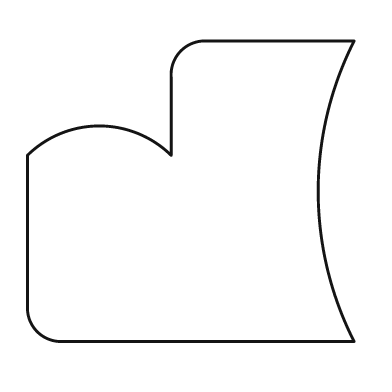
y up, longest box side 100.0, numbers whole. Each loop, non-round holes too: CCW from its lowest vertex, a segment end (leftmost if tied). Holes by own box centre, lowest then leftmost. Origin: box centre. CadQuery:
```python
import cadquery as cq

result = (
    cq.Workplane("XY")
    .moveTo(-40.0, -46.0)
    .lineTo(50.0, -46.0)
    .threePointArc((39.0, 0.0), (50.0, 46.0))
    .lineTo(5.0, 46.0)
    .threePointArc((-3.0, 43.0), (-6.0, 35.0))
    .lineTo(-6.0, 11.0)
    .threePointArc((-28.0, 20.0), (-50.0, 11.0))
    .lineTo(-50.0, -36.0)
    .threePointArc((-47.0, -43.0), (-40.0, -46.0))
    .close()
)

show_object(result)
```